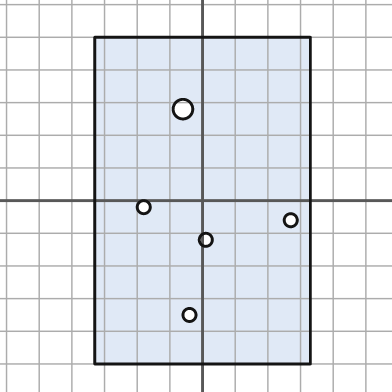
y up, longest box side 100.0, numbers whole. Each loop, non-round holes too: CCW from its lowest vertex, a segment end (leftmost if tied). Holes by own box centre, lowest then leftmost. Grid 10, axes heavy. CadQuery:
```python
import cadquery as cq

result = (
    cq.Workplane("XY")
    .moveTo(-33.0, -50.0)
    .lineTo(33.0, -50.0)
    .lineTo(33.0, 50.0)
    .lineTo(-33.0, 50.0)
    .close()
    .moveTo(-4.0, -35.0)
    .circle(2.0)
    .moveTo(1.0, -12.0)
    .circle(2.0)
    .moveTo(27.0, -6.0)
    .circle(2.0)
    .moveTo(-18.0, -2.0)
    .circle(2.0)
    .moveTo(-6.0, 28.0)
    .circle(3.0)
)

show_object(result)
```